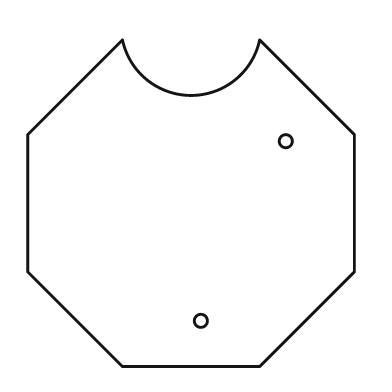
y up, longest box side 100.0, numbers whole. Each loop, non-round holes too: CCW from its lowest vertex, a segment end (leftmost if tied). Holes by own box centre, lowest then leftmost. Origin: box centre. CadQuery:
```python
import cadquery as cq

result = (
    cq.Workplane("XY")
    .moveTo(-21.0, -50.0)
    .lineTo(21.0, -50.0)
    .lineTo(50.0, -21.0)
    .lineTo(50.0, 21.0)
    .lineTo(21.0, 50.0)
    .threePointArc((0.0, 33.0), (-21.0, 50.0))
    .lineTo(-50.0, 21.0)
    .lineTo(-50.0, -21.0)
    .close()
    .moveTo(3.0, -36.0)
    .circle(2.0)
    .moveTo(29.0, 19.0)
    .circle(2.0)
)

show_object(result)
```